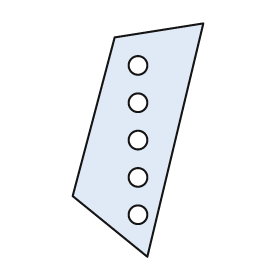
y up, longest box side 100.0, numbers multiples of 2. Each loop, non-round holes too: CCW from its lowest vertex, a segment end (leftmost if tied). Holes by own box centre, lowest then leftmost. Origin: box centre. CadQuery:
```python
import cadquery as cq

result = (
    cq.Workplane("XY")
    .moveTo(4.0, -50.0)
    .lineTo(28.0, 50.0)
    .lineTo(-10.0, 44.0)
    .lineTo(-28.0, -24.0)
    .close()
    .moveTo(0.0, -32.0)
    .circle(4.0)
    .moveTo(0.0, -16.0)
    .circle(4.0)
    .moveTo(0.0, 0.0)
    .circle(4.0)
    .moveTo(0.0, 16.0)
    .circle(4.0)
    .moveTo(0.0, 32.0)
    .circle(4.0)
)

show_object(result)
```